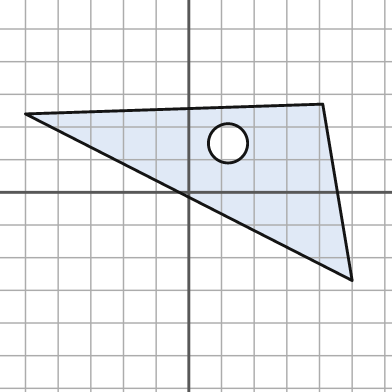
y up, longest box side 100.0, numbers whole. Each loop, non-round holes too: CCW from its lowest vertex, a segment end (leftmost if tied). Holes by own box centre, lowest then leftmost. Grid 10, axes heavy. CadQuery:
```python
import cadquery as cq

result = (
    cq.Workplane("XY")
    .moveTo(50.0, -27.0)
    .lineTo(41.0, 27.0)
    .lineTo(-50.0, 24.0)
    .close()
    .moveTo(12.0, 15.0)
    .circle(6.0)
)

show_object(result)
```